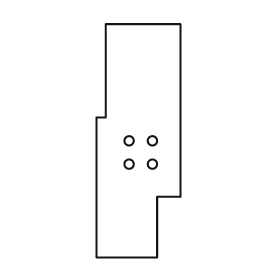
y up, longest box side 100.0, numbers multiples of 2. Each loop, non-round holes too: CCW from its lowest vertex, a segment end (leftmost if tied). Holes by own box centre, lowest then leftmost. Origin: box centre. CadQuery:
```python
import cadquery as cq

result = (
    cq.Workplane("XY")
    .moveTo(-18.0, -50.0)
    .lineTo(8.0, -50.0)
    .lineTo(8.0, -24.0)
    .lineTo(18.0, -24.0)
    .lineTo(18.0, 50.0)
    .lineTo(-14.0, 50.0)
    .lineTo(-14.0, 10.0)
    .lineTo(-18.0, 10.0)
    .close()
    .moveTo(-4.0, -10.0)
    .circle(2.0)
    .moveTo(6.0, -10.0)
    .circle(2.0)
    .moveTo(-4.0, 0.0)
    .circle(2.0)
    .moveTo(6.0, 0.0)
    .circle(2.0)
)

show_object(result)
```